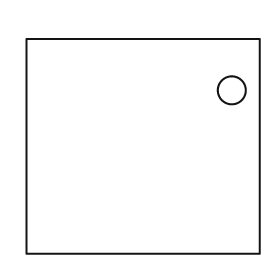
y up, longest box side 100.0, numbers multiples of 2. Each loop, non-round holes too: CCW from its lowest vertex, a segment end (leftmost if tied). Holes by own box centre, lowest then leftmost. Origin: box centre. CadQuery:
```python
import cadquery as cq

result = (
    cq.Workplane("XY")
    .moveTo(-50.0, -46.0)
    .lineTo(50.0, -46.0)
    .lineTo(50.0, 46.0)
    .lineTo(-50.0, 46.0)
    .close()
    .moveTo(38.0, 24.0)
    .circle(6.0)
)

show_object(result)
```